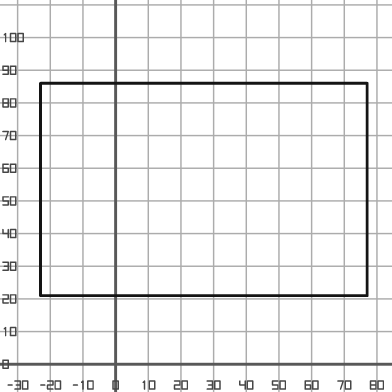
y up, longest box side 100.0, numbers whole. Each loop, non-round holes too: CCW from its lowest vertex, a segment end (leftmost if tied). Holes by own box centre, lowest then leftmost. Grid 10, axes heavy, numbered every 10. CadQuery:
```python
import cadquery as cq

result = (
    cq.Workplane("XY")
    .moveTo(-23.0, 21.0)
    .lineTo(77.0, 21.0)
    .lineTo(77.0, 86.0)
    .lineTo(-23.0, 86.0)
    .close()
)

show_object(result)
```